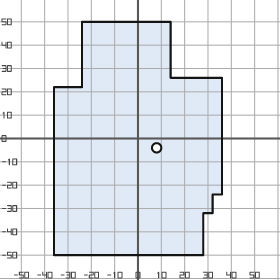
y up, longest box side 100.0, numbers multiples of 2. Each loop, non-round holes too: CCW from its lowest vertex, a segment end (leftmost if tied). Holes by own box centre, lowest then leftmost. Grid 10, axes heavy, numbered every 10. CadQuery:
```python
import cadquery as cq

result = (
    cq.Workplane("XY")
    .moveTo(-36.0, -50.0)
    .lineTo(28.0, -50.0)
    .lineTo(28.0, -32.0)
    .lineTo(32.0, -32.0)
    .lineTo(32.0, -24.0)
    .lineTo(36.0, -24.0)
    .lineTo(36.0, 26.0)
    .lineTo(14.0, 26.0)
    .lineTo(14.0, 50.0)
    .lineTo(-24.0, 50.0)
    .lineTo(-24.0, 22.0)
    .lineTo(-36.0, 22.0)
    .close()
    .moveTo(8.0, -4.0)
    .circle(2.0)
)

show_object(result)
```